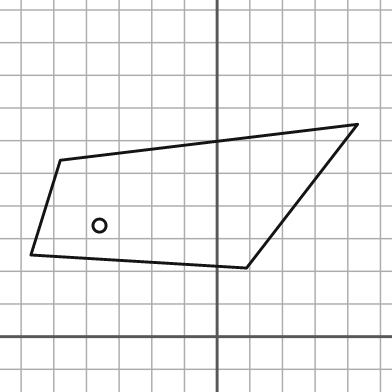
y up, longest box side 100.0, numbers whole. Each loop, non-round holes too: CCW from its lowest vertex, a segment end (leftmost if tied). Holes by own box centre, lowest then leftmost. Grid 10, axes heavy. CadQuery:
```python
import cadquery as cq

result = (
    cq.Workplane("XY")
    .moveTo(9.0, 21.0)
    .lineTo(43.0, 65.0)
    .lineTo(-48.0, 54.0)
    .lineTo(-57.0, 25.0)
    .close()
    .moveTo(-36.0, 34.0)
    .circle(2.0)
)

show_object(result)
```